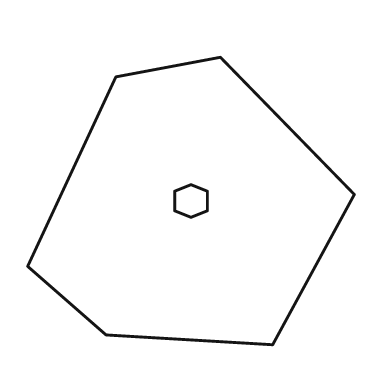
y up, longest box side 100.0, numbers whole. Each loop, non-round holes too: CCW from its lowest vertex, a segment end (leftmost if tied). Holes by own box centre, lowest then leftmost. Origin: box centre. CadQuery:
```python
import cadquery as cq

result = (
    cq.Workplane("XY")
    .moveTo(25.0, -44.0)
    .lineTo(50.0, 2.0)
    .lineTo(9.0, 44.0)
    .lineTo(-23.0, 38.0)
    .lineTo(-50.0, -20.0)
    .lineTo(-26.0, -41.0)
    .close()
    .moveTo(0.0, -5.0)
    .lineTo(5.0, -3.0)
    .lineTo(5.0, 3.0)
    .lineTo(0.0, 5.0)
    .lineTo(-5.0, 3.0)
    .lineTo(-5.0, -3.0)
    .close()
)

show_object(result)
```